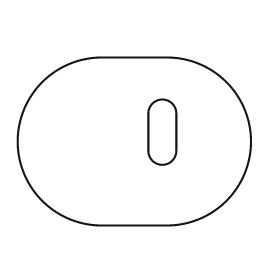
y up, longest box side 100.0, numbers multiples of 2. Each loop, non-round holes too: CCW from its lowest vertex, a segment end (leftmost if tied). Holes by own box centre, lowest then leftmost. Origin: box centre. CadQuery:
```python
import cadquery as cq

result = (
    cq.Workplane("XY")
    .moveTo(-14.0, -36.0)
    .lineTo(14.0, -36.0)
    .threePointArc((50.0, 0.0), (14.0, 36.0))
    .lineTo(-14.0, 36.0)
    .threePointArc((-50.0, 0.0), (-14.0, -36.0))
    .close()
    .moveTo(6.0, -4.0)
    .threePointArc((12.0, -10.0), (18.0, -4.0))
    .lineTo(18.0, 12.0)
    .threePointArc((12.0, 18.0), (6.0, 12.0))
    .close()
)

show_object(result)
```